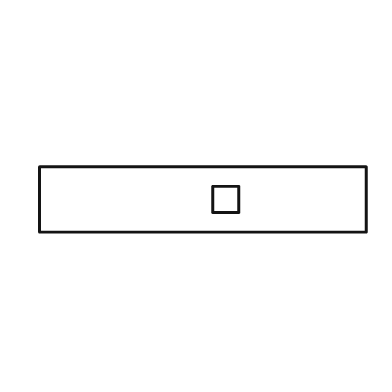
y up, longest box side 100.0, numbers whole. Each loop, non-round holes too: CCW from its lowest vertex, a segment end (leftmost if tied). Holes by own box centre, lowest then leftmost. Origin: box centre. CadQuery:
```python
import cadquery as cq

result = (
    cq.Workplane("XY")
    .moveTo(-50.0, -10.0)
    .lineTo(50.0, -10.0)
    .lineTo(50.0, 10.0)
    .lineTo(-50.0, 10.0)
    .close()
    .moveTo(3.0, -4.0)
    .lineTo(11.0, -4.0)
    .lineTo(11.0, 4.0)
    .lineTo(3.0, 4.0)
    .close()
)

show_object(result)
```